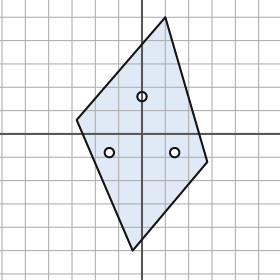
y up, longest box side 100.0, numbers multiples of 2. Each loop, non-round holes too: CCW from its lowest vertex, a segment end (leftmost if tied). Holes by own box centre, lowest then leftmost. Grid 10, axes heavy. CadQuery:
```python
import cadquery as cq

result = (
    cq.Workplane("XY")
    .moveTo(-4.0, -50.0)
    .lineTo(28.0, -12.0)
    .lineTo(10.0, 50.0)
    .lineTo(-28.0, 6.0)
    .close()
    .moveTo(-14.0, -8.0)
    .circle(2.0)
    .moveTo(14.0, -8.0)
    .circle(2.0)
    .moveTo(0.0, 16.0)
    .circle(2.0)
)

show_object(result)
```